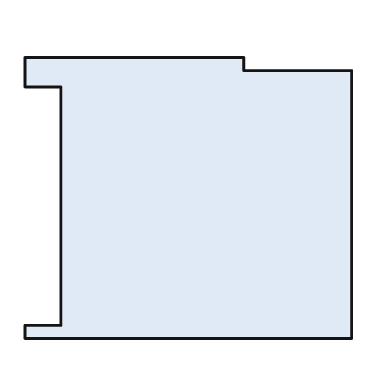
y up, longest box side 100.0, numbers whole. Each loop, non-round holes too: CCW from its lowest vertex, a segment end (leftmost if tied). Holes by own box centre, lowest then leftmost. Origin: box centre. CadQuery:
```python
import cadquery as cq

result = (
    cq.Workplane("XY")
    .moveTo(-50.0, -43.0)
    .lineTo(50.0, -43.0)
    .lineTo(50.0, 39.0)
    .lineTo(17.0, 39.0)
    .lineTo(17.0, 43.0)
    .lineTo(-50.0, 43.0)
    .lineTo(-50.0, 34.0)
    .lineTo(-39.0, 34.0)
    .lineTo(-39.0, -39.0)
    .lineTo(-50.0, -39.0)
    .close()
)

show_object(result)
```